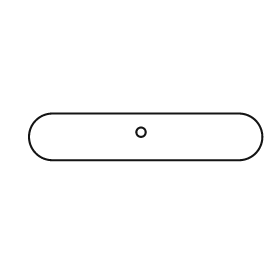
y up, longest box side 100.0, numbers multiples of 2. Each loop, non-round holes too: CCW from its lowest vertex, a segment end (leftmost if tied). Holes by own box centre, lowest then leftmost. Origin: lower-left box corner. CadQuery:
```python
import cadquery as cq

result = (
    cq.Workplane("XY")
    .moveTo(10.0, 0.0)
    .lineTo(90.0, 0.0)
    .threePointArc((100.0, 10.0), (90.0, 20.0))
    .lineTo(10.0, 20.0)
    .threePointArc((0.0, 10.0), (10.0, 0.0))
    .close()
    .moveTo(48.0, 12.0)
    .circle(2.0)
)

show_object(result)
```